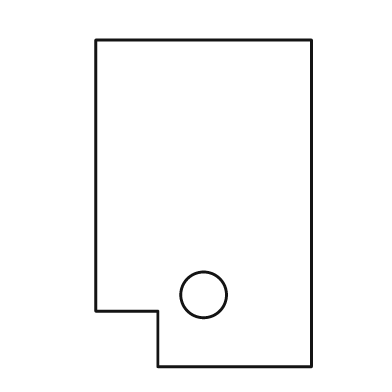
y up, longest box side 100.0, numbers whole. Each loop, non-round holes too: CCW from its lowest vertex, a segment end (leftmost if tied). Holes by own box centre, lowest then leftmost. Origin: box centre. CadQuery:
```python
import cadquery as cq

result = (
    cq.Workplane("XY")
    .moveTo(-14.0, -50.0)
    .lineTo(33.0, -50.0)
    .lineTo(33.0, 50.0)
    .lineTo(-33.0, 50.0)
    .lineTo(-33.0, -33.0)
    .lineTo(-14.0, -33.0)
    .close()
    .moveTo(0.0, -28.0)
    .circle(7.0)
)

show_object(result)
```